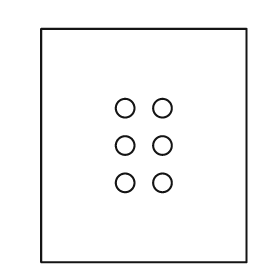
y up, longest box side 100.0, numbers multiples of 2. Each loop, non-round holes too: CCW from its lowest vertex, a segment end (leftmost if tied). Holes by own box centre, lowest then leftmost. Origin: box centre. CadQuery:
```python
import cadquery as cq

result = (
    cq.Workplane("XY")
    .moveTo(-44.0, -50.0)
    .lineTo(44.0, -50.0)
    .lineTo(44.0, 50.0)
    .lineTo(-44.0, 50.0)
    .close()
    .moveTo(-8.0, -16.0)
    .circle(4.0)
    .moveTo(8.0, -16.0)
    .circle(4.0)
    .moveTo(-8.0, 0.0)
    .circle(4.0)
    .moveTo(8.0, 0.0)
    .circle(4.0)
    .moveTo(-8.0, 16.0)
    .circle(4.0)
    .moveTo(8.0, 16.0)
    .circle(4.0)
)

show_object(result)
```